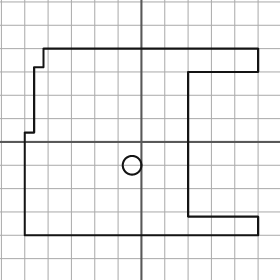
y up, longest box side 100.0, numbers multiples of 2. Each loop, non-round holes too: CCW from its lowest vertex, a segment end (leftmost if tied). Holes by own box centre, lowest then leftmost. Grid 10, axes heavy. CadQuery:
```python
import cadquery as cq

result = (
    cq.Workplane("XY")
    .moveTo(-50.0, -40.0)
    .lineTo(50.0, -40.0)
    .lineTo(50.0, -32.0)
    .lineTo(20.0, -32.0)
    .lineTo(20.0, 30.0)
    .lineTo(50.0, 30.0)
    .lineTo(50.0, 40.0)
    .lineTo(-42.0, 40.0)
    .lineTo(-42.0, 32.0)
    .lineTo(-46.0, 32.0)
    .lineTo(-46.0, 4.0)
    .lineTo(-50.0, 4.0)
    .close()
    .moveTo(-4.0, -10.0)
    .circle(4.0)
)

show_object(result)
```